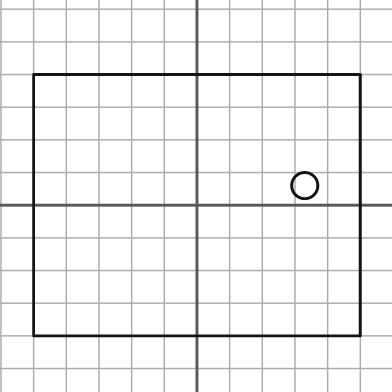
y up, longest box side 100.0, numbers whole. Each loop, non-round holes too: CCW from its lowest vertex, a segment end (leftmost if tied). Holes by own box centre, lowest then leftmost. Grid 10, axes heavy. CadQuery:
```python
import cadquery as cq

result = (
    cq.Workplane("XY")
    .moveTo(-50.0, -40.0)
    .lineTo(50.0, -40.0)
    .lineTo(50.0, 40.0)
    .lineTo(-50.0, 40.0)
    .close()
    .moveTo(33.0, 6.0)
    .circle(4.0)
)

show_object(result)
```